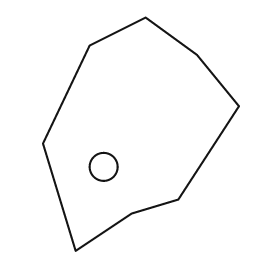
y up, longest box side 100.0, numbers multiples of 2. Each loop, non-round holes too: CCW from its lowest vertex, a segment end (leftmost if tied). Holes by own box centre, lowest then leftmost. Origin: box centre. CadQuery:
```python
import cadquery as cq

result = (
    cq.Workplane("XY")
    .moveTo(-28.0, -50.0)
    .lineTo(-4.0, -34.0)
    .lineTo(16.0, -28.0)
    .lineTo(42.0, 12.0)
    .lineTo(24.0, 34.0)
    .lineTo(2.0, 50.0)
    .lineTo(-22.0, 38.0)
    .lineTo(-42.0, -4.0)
    .close()
    .moveTo(-16.0, -14.0)
    .circle(6.0)
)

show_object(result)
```